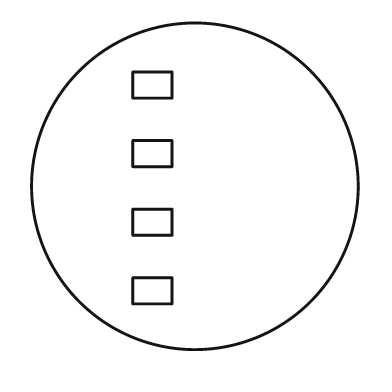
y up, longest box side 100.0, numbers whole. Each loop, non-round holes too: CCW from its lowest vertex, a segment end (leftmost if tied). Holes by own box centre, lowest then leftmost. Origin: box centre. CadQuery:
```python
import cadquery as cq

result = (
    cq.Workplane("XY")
    .moveTo(0.0, 0.0)
    .circle(50.0)
    .moveTo(-19.0, -36.0)
    .lineTo(-7.0, -36.0)
    .lineTo(-7.0, -28.0)
    .lineTo(-19.0, -28.0)
    .close()
    .moveTo(-19.0, -15.0)
    .lineTo(-7.0, -15.0)
    .lineTo(-7.0, -7.0)
    .lineTo(-19.0, -7.0)
    .close()
    .moveTo(-19.0, 6.0)
    .lineTo(-7.0, 6.0)
    .lineTo(-7.0, 14.0)
    .lineTo(-19.0, 14.0)
    .close()
    .moveTo(-19.0, 27.0)
    .lineTo(-7.0, 27.0)
    .lineTo(-7.0, 35.0)
    .lineTo(-19.0, 35.0)
    .close()
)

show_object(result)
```